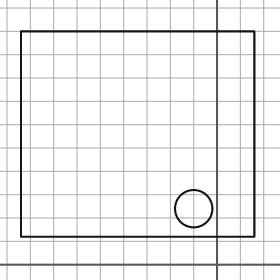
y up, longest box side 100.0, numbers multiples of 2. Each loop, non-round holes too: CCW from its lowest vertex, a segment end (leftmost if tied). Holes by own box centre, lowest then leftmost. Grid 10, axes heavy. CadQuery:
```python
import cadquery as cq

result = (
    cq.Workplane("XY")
    .moveTo(-84.0, 12.0)
    .lineTo(16.0, 12.0)
    .lineTo(16.0, 100.0)
    .lineTo(-84.0, 100.0)
    .close()
    .moveTo(-10.0, 24.0)
    .circle(8.0)
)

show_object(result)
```